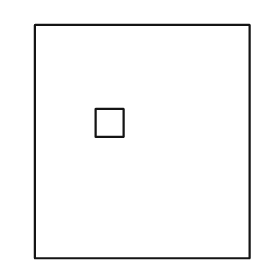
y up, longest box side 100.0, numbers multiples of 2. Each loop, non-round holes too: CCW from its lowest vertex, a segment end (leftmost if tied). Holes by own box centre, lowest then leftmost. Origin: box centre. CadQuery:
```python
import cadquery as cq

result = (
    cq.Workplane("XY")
    .moveTo(-46.0, -50.0)
    .lineTo(46.0, -50.0)
    .lineTo(46.0, 50.0)
    .lineTo(-46.0, 50.0)
    .close()
    .moveTo(-20.0, 2.0)
    .lineTo(-8.0, 2.0)
    .lineTo(-8.0, 14.0)
    .lineTo(-20.0, 14.0)
    .close()
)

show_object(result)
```